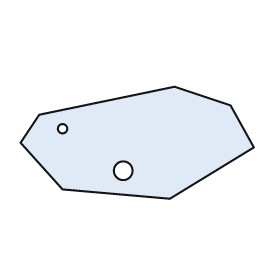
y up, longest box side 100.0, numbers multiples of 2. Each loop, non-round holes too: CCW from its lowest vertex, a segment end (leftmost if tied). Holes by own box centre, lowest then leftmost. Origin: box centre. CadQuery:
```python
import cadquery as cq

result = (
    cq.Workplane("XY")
    .moveTo(14.0, -24.0)
    .lineTo(50.0, -2.0)
    .lineTo(40.0, 16.0)
    .lineTo(16.0, 24.0)
    .lineTo(-42.0, 12.0)
    .lineTo(-50.0, 0.0)
    .lineTo(-32.0, -20.0)
    .close()
    .moveTo(-6.0, -12.0)
    .circle(4.0)
    .moveTo(-32.0, 6.0)
    .circle(2.0)
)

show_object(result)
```